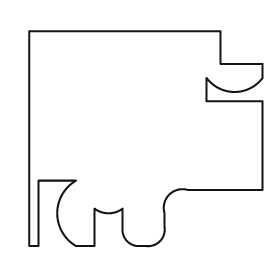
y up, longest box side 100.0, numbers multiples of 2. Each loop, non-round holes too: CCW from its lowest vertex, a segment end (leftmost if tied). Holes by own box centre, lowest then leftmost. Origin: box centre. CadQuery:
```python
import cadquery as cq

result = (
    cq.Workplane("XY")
    .moveTo(-50.0, -46.0)
    .lineTo(-46.0, -46.0)
    .lineTo(-46.0, -18.0)
    .lineTo(-30.0, -18.0)
    .threePointArc((-38.0, -32.0), (-30.0, -46.0))
    .lineTo(-22.0, -46.0)
    .lineTo(-22.0, -30.0)
    .threePointArc((-16.0, -32.0), (-10.0, -30.0))
    .lineTo(-10.0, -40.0)
    .threePointArc((-8.0, -44.0), (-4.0, -46.0))
    .lineTo(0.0, -46.0)
    .threePointArc((6.0, -44.0), (8.0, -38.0))
    .lineTo(8.0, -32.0)
    .threePointArc((10.0, -24.0), (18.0, -22.0))
    .lineTo(50.0, -22.0)
    .lineTo(50.0, 16.0)
    .lineTo(26.0, 16.0)
    .lineTo(26.0, 26.0)
    .threePointArc((38.0, 20.0), (50.0, 26.0))
    .lineTo(50.0, 32.0)
    .lineTo(32.0, 32.0)
    .lineTo(32.0, 46.0)
    .lineTo(-50.0, 46.0)
    .close()
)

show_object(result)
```